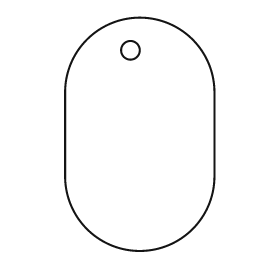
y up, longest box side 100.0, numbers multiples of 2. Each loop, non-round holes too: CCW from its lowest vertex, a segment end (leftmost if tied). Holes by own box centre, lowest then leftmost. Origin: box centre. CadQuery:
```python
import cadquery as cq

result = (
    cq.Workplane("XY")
    .moveTo(-32.0, -18.0)
    .threePointArc((0.0, -50.0), (32.0, -18.0))
    .lineTo(32.0, 18.0)
    .threePointArc((0.0, 50.0), (-32.0, 18.0))
    .close()
    .moveTo(-4.0, 36.0)
    .circle(4.0)
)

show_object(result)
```